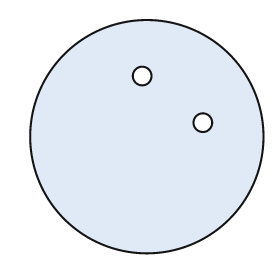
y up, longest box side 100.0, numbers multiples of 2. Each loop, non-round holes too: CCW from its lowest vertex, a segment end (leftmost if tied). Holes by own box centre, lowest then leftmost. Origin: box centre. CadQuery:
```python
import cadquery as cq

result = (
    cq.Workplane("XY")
    .moveTo(0.0, 0.0)
    .circle(50.0)
    .moveTo(24.0, 6.0)
    .circle(4.0)
    .moveTo(-2.0, 26.0)
    .circle(4.0)
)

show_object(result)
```